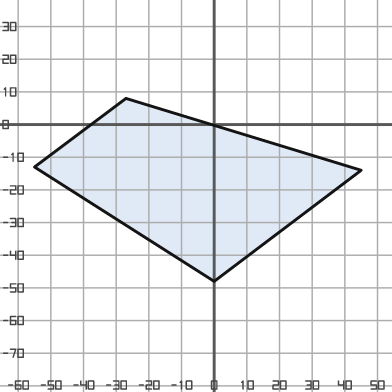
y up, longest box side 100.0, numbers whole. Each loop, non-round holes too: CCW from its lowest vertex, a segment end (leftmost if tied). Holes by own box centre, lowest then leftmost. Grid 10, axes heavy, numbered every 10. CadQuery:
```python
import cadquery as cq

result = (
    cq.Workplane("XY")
    .moveTo(0.0, -48.0)
    .lineTo(45.0, -14.0)
    .lineTo(-27.0, 8.0)
    .lineTo(-55.0, -13.0)
    .close()
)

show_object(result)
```